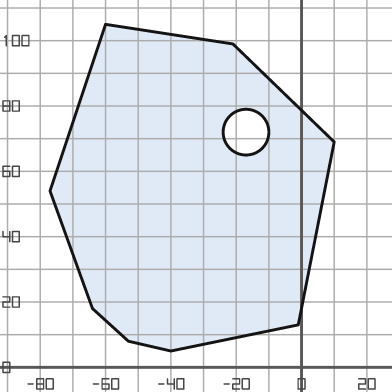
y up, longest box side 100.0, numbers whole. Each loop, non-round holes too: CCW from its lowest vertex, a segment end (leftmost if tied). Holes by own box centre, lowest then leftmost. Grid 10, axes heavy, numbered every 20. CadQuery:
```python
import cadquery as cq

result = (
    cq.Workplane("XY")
    .moveTo(-40.0, 5.0)
    .lineTo(-1.0, 13.0)
    .lineTo(10.0, 69.0)
    .lineTo(-21.0, 99.0)
    .lineTo(-60.0, 105.0)
    .lineTo(-77.0, 54.0)
    .lineTo(-64.0, 18.0)
    .lineTo(-53.0, 8.0)
    .close()
    .moveTo(-17.0, 72.0)
    .circle(7.0)
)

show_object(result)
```